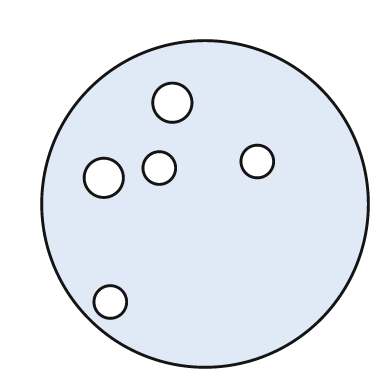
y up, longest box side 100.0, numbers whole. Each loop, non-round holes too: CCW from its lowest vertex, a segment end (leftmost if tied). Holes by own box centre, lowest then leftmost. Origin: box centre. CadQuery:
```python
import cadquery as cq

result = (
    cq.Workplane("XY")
    .moveTo(0.0, 0.0)
    .circle(50.0)
    .moveTo(-29.0, -30.0)
    .circle(5.0)
    .moveTo(-31.0, 8.0)
    .circle(6.0)
    .moveTo(-14.0, 11.0)
    .circle(5.0)
    .moveTo(16.0, 13.0)
    .circle(5.0)
    .moveTo(-10.0, 31.0)
    .circle(6.0)
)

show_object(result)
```